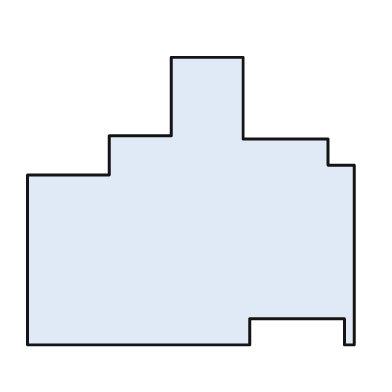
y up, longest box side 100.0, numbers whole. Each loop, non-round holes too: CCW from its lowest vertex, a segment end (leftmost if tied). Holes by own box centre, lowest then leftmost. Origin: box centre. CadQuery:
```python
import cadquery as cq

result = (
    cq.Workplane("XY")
    .moveTo(-50.0, -44.0)
    .lineTo(18.0, -44.0)
    .lineTo(18.0, -36.0)
    .lineTo(47.0, -36.0)
    .lineTo(47.0, -44.0)
    .lineTo(50.0, -44.0)
    .lineTo(50.0, 11.0)
    .lineTo(42.0, 11.0)
    .lineTo(42.0, 19.0)
    .lineTo(16.0, 19.0)
    .lineTo(16.0, 44.0)
    .lineTo(-6.0, 44.0)
    .lineTo(-6.0, 20.0)
    .lineTo(-25.0, 20.0)
    .lineTo(-25.0, 8.0)
    .lineTo(-50.0, 8.0)
    .close()
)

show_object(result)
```